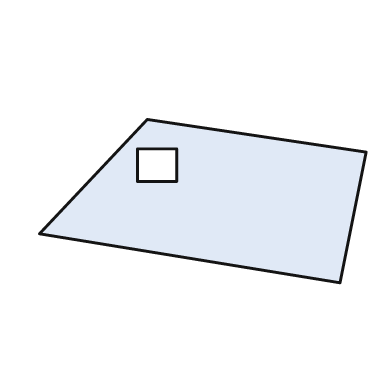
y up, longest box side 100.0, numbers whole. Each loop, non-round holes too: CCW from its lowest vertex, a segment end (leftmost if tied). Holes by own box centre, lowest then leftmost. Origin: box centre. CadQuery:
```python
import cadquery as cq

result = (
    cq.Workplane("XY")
    .moveTo(42.0, -25.0)
    .lineTo(50.0, 15.0)
    .lineTo(-17.0, 25.0)
    .lineTo(-50.0, -10.0)
    .close()
    .moveTo(-20.0, 6.0)
    .lineTo(-8.0, 6.0)
    .lineTo(-8.0, 16.0)
    .lineTo(-20.0, 16.0)
    .close()
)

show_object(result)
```